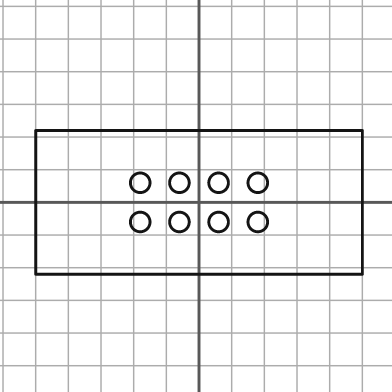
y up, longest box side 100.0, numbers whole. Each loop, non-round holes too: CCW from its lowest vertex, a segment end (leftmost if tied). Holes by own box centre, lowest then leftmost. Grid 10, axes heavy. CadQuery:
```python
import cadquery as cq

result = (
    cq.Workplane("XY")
    .moveTo(-50.0, -22.0)
    .lineTo(50.0, -22.0)
    .lineTo(50.0, 22.0)
    .lineTo(-50.0, 22.0)
    .close()
    .moveTo(-18.0, -6.0)
    .circle(3.0)
    .moveTo(-6.0, -6.0)
    .circle(3.0)
    .moveTo(6.0, -6.0)
    .circle(3.0)
    .moveTo(18.0, -6.0)
    .circle(3.0)
    .moveTo(-18.0, 6.0)
    .circle(3.0)
    .moveTo(-6.0, 6.0)
    .circle(3.0)
    .moveTo(6.0, 6.0)
    .circle(3.0)
    .moveTo(18.0, 6.0)
    .circle(3.0)
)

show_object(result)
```